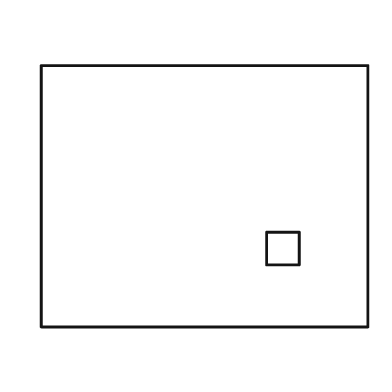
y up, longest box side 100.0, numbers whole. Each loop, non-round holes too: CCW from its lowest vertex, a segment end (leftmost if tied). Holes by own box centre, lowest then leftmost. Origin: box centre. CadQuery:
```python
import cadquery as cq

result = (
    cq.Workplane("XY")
    .moveTo(-50.0, -40.0)
    .lineTo(50.0, -40.0)
    .lineTo(50.0, 40.0)
    .lineTo(-50.0, 40.0)
    .close()
    .moveTo(19.0, -21.0)
    .lineTo(29.0, -21.0)
    .lineTo(29.0, -11.0)
    .lineTo(19.0, -11.0)
    .close()
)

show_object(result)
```